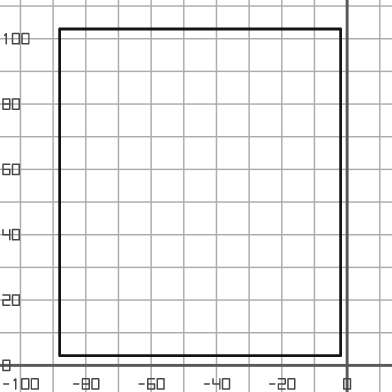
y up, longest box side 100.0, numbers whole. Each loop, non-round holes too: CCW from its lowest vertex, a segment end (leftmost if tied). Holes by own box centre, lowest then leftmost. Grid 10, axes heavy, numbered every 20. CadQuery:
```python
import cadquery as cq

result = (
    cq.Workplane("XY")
    .moveTo(-88.0, 3.0)
    .lineTo(-2.0, 3.0)
    .lineTo(-2.0, 103.0)
    .lineTo(-88.0, 103.0)
    .close()
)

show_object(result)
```